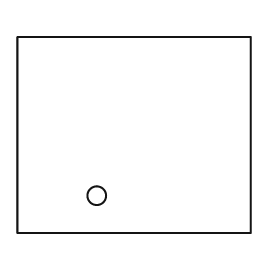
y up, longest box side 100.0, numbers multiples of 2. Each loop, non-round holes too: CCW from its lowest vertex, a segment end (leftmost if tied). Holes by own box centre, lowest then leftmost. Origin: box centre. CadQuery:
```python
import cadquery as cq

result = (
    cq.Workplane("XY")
    .moveTo(-50.0, -42.0)
    .lineTo(50.0, -42.0)
    .lineTo(50.0, 42.0)
    .lineTo(-50.0, 42.0)
    .close()
    .moveTo(-16.0, -26.0)
    .circle(4.0)
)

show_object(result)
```